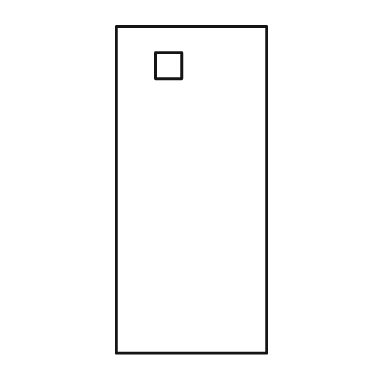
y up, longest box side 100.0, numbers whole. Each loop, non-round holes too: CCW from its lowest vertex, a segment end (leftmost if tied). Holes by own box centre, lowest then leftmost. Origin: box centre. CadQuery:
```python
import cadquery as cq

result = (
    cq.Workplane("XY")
    .moveTo(-23.0, -50.0)
    .lineTo(23.0, -50.0)
    .lineTo(23.0, 50.0)
    .lineTo(-23.0, 50.0)
    .close()
    .moveTo(-11.0, 34.0)
    .lineTo(-3.0, 34.0)
    .lineTo(-3.0, 42.0)
    .lineTo(-11.0, 42.0)
    .close()
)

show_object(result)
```